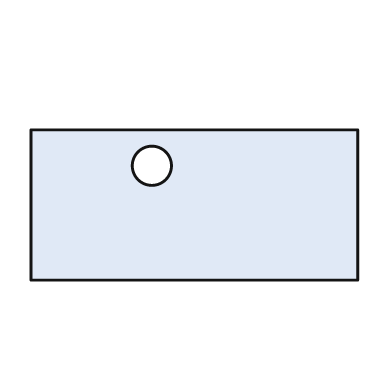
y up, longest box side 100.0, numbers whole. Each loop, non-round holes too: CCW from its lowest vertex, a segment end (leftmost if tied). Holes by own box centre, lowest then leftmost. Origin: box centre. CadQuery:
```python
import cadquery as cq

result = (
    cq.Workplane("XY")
    .moveTo(-50.0, -23.0)
    .lineTo(50.0, -23.0)
    .lineTo(50.0, 23.0)
    .lineTo(-50.0, 23.0)
    .close()
    .moveTo(-13.0, 12.0)
    .circle(6.0)
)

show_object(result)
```